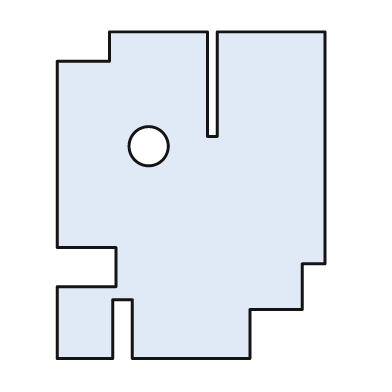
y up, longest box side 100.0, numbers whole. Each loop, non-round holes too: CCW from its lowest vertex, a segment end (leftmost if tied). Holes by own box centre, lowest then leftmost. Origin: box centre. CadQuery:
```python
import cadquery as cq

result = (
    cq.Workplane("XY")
    .moveTo(-41.0, -50.0)
    .lineTo(-24.0, -50.0)
    .lineTo(-24.0, -32.0)
    .lineTo(-18.0, -32.0)
    .lineTo(-18.0, -50.0)
    .lineTo(18.0, -50.0)
    .lineTo(18.0, -35.0)
    .lineTo(34.0, -35.0)
    .lineTo(34.0, -21.0)
    .lineTo(41.0, -21.0)
    .lineTo(41.0, 50.0)
    .lineTo(8.0, 50.0)
    .lineTo(8.0, 18.0)
    .lineTo(5.0, 18.0)
    .lineTo(5.0, 50.0)
    .lineTo(-25.0, 50.0)
    .lineTo(-25.0, 41.0)
    .lineTo(-41.0, 41.0)
    .lineTo(-41.0, -16.0)
    .lineTo(-23.0, -16.0)
    .lineTo(-23.0, -28.0)
    .lineTo(-41.0, -28.0)
    .close()
    .moveTo(-13.0, 15.0)
    .circle(6.0)
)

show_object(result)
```